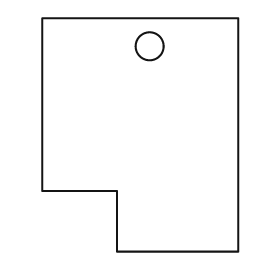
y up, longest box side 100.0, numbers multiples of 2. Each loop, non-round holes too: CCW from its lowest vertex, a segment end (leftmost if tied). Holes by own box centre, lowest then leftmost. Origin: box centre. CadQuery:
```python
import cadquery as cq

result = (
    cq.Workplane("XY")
    .moveTo(-10.0, -50.0)
    .lineTo(42.0, -50.0)
    .lineTo(42.0, 50.0)
    .lineTo(-42.0, 50.0)
    .lineTo(-42.0, -24.0)
    .lineTo(-10.0, -24.0)
    .close()
    .moveTo(4.0, 38.0)
    .circle(6.0)
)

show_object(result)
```